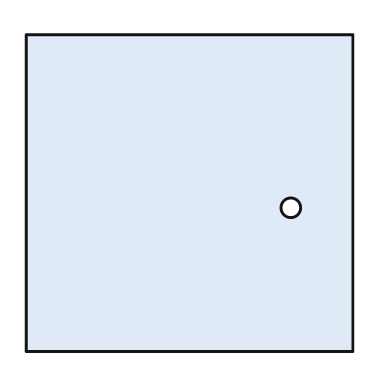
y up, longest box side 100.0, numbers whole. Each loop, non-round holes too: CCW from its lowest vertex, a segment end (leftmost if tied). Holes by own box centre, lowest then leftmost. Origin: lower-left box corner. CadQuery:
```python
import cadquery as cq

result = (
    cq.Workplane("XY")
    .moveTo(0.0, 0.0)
    .lineTo(100.0, 0.0)
    .lineTo(100.0, 97.0)
    .lineTo(0.0, 97.0)
    .close()
    .moveTo(81.0, 44.0)
    .circle(3.0)
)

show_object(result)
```